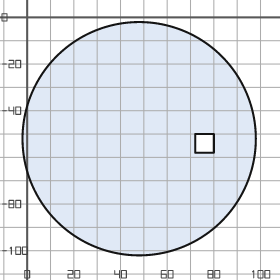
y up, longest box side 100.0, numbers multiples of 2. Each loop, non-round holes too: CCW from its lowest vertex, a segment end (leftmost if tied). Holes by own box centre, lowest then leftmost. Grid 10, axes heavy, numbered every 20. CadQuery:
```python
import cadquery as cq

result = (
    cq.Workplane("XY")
    .moveTo(48.0, -52.0)
    .circle(50.0)
    .moveTo(72.0, -58.0)
    .lineTo(80.0, -58.0)
    .lineTo(80.0, -50.0)
    .lineTo(72.0, -50.0)
    .close()
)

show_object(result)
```